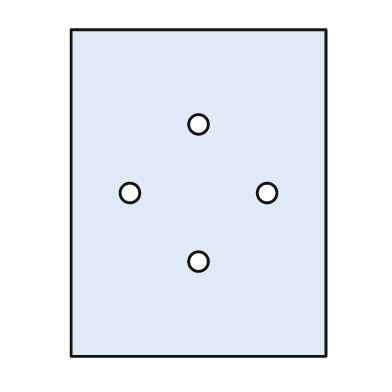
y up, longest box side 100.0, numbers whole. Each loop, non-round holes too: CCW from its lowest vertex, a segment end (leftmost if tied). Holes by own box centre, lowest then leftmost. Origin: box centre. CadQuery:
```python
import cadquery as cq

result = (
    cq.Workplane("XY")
    .moveTo(-39.0, -50.0)
    .lineTo(39.0, -50.0)
    .lineTo(39.0, 50.0)
    .lineTo(-39.0, 50.0)
    .close()
    .moveTo(0.0, -21.0)
    .circle(3.0)
    .moveTo(-21.0, 0.0)
    .circle(3.0)
    .moveTo(21.0, 0.0)
    .circle(3.0)
    .moveTo(0.0, 21.0)
    .circle(3.0)
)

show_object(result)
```